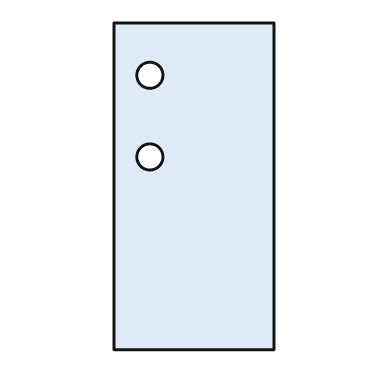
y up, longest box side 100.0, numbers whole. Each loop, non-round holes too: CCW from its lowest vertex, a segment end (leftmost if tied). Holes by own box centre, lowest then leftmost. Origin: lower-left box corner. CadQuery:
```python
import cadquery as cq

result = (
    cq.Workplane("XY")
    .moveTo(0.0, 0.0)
    .lineTo(49.0, 0.0)
    .lineTo(49.0, 100.0)
    .lineTo(0.0, 100.0)
    .close()
    .moveTo(11.0, 59.0)
    .circle(4.0)
    .moveTo(11.0, 84.0)
    .circle(4.0)
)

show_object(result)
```